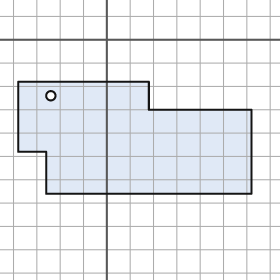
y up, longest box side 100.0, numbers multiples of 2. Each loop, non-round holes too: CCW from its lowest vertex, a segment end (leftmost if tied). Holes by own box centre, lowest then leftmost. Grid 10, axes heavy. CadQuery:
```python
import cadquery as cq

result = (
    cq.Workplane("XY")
    .moveTo(-26.0, -66.0)
    .lineTo(62.0, -66.0)
    .lineTo(62.0, -30.0)
    .lineTo(18.0, -30.0)
    .lineTo(18.0, -18.0)
    .lineTo(-38.0, -18.0)
    .lineTo(-38.0, -48.0)
    .lineTo(-26.0, -48.0)
    .close()
    .moveTo(-24.0, -24.0)
    .circle(2.0)
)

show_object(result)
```